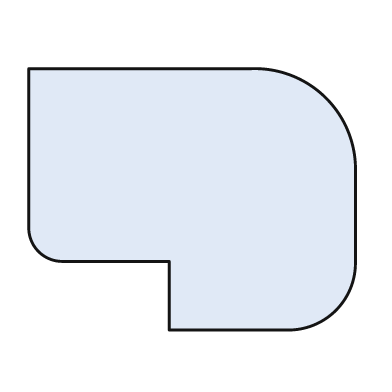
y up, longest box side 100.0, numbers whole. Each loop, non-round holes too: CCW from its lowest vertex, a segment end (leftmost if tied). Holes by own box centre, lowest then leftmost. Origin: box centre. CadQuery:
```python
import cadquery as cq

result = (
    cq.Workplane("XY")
    .moveTo(-7.0, -40.0)
    .lineTo(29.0, -40.0)
    .threePointArc((44.0, -34.0), (50.0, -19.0))
    .lineTo(50.0, 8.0)
    .threePointArc((41.0, 31.0), (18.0, 40.0))
    .lineTo(-50.0, 40.0)
    .lineTo(-50.0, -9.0)
    .threePointArc((-47.0, -16.0), (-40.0, -19.0))
    .lineTo(-7.0, -19.0)
    .close()
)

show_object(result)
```